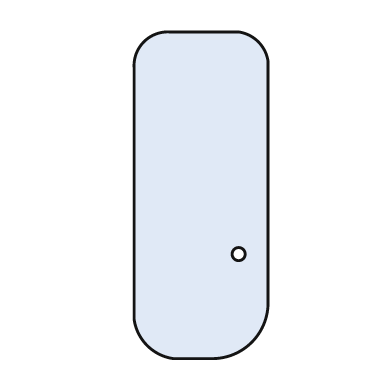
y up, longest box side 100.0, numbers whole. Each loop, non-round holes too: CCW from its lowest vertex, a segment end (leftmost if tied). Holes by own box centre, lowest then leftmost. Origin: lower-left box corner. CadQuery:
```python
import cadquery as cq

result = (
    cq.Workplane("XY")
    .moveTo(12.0, 0.0)
    .lineTo(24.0, 0.0)
    .threePointArc((36.0, 5.0), (41.0, 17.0))
    .lineTo(41.0, 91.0)
    .threePointArc((38.0, 97.0), (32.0, 100.0))
    .lineTo(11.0, 100.0)
    .threePointArc((3.0, 97.0), (0.0, 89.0))
    .lineTo(0.0, 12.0)
    .threePointArc((4.0, 4.0), (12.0, 0.0))
    .close()
    .moveTo(32.0, 32.0)
    .circle(2.0)
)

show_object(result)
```